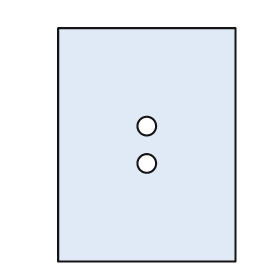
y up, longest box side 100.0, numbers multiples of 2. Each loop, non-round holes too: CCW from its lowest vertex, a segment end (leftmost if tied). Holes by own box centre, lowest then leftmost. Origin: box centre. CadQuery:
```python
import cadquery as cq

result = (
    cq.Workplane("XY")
    .moveTo(-38.0, -50.0)
    .lineTo(38.0, -50.0)
    .lineTo(38.0, 50.0)
    .lineTo(-38.0, 50.0)
    .close()
    .moveTo(0.0, -8.0)
    .circle(4.0)
    .moveTo(0.0, 8.0)
    .circle(4.0)
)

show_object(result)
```